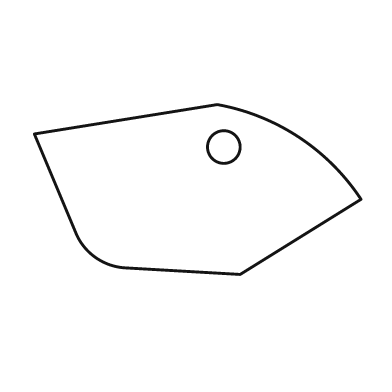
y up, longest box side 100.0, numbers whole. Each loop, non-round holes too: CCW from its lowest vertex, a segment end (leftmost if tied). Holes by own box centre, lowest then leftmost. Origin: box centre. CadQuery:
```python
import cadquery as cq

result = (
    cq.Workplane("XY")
    .moveTo(13.0, -26.0)
    .lineTo(50.0, -3.0)
    .threePointArc((31.0, 16.0), (6.0, 26.0))
    .lineTo(-50.0, 17.0)
    .lineTo(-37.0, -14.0)
    .threePointArc((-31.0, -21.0), (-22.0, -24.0))
    .close()
    .moveTo(8.0, 13.0)
    .circle(5.0)
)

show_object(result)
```